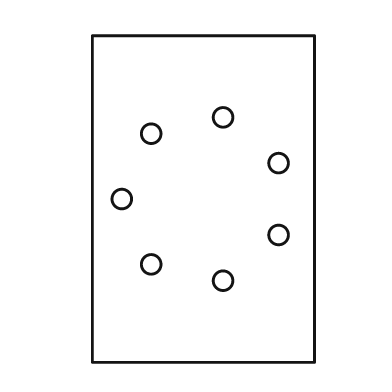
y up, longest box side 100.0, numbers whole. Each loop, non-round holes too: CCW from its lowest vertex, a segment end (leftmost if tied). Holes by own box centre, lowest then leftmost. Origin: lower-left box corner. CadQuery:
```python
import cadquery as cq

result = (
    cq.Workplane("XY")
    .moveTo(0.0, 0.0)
    .lineTo(68.0, 0.0)
    .lineTo(68.0, 100.0)
    .lineTo(0.0, 100.0)
    .close()
    .moveTo(40.0, 25.0)
    .circle(3.0)
    .moveTo(18.0, 30.0)
    .circle(3.0)
    .moveTo(57.0, 39.0)
    .circle(3.0)
    .moveTo(9.0, 50.0)
    .circle(3.0)
    .moveTo(57.0, 61.0)
    .circle(3.0)
    .moveTo(18.0, 70.0)
    .circle(3.0)
    .moveTo(40.0, 75.0)
    .circle(3.0)
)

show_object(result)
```